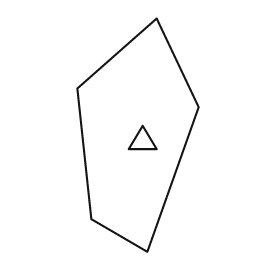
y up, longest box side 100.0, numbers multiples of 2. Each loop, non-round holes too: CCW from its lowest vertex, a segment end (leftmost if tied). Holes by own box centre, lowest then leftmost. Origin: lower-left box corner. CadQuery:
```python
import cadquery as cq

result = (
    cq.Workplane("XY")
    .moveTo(30.0, 0.0)
    .lineTo(52.0, 62.0)
    .lineTo(34.0, 100.0)
    .lineTo(0.0, 70.0)
    .lineTo(6.0, 14.0)
    .close()
    .moveTo(22.0, 44.0)
    .lineTo(34.0, 44.0)
    .lineTo(28.0, 54.0)
    .close()
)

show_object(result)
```